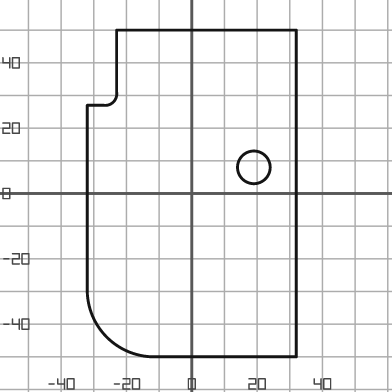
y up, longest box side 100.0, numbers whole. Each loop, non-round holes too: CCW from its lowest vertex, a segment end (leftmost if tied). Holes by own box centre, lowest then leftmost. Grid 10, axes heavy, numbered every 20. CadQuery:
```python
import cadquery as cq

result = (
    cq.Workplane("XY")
    .moveTo(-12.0, -50.0)
    .lineTo(32.0, -50.0)
    .lineTo(32.0, 50.0)
    .lineTo(-23.0, 50.0)
    .lineTo(-23.0, 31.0)
    .threePointArc((-24.0, 28.0), (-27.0, 27.0))
    .lineTo(-32.0, 27.0)
    .lineTo(-32.0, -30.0)
    .threePointArc((-26.0, -44.0), (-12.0, -50.0))
    .close()
    .moveTo(19.0, 8.0)
    .circle(5.0)
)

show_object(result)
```